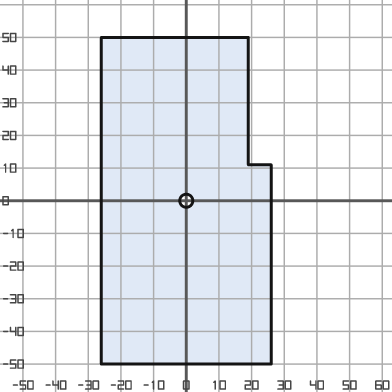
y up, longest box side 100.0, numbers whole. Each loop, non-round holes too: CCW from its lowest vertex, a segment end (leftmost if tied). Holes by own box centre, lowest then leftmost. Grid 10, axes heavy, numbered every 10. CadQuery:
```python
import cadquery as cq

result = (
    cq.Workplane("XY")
    .moveTo(-26.0, -50.0)
    .lineTo(26.0, -50.0)
    .lineTo(26.0, 11.0)
    .lineTo(19.0, 11.0)
    .lineTo(19.0, 50.0)
    .lineTo(-26.0, 50.0)
    .close()
    .moveTo(0.0, 0.0)
    .circle(2.0)
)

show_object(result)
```